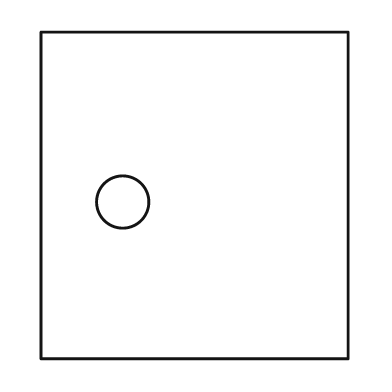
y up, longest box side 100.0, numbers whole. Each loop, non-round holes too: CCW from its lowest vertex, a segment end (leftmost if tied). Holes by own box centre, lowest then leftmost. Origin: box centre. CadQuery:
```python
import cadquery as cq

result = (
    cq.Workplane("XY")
    .moveTo(-47.0, -50.0)
    .lineTo(47.0, -50.0)
    .lineTo(47.0, 50.0)
    .lineTo(-47.0, 50.0)
    .close()
    .moveTo(-22.0, -2.0)
    .circle(8.0)
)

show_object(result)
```